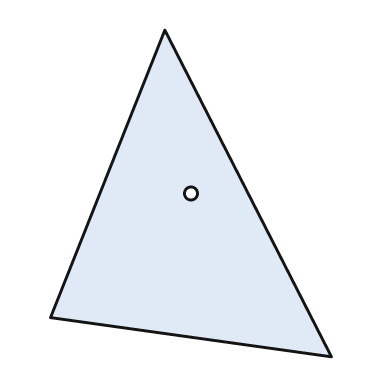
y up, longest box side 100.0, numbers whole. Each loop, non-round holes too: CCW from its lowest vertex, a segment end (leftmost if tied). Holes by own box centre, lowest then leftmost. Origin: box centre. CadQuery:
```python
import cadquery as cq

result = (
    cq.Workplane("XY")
    .moveTo(43.0, -50.0)
    .lineTo(-8.0, 50.0)
    .lineTo(-43.0, -38.0)
    .close()
    .moveTo(0.0, 0.0)
    .circle(2.0)
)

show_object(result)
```